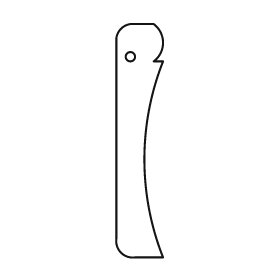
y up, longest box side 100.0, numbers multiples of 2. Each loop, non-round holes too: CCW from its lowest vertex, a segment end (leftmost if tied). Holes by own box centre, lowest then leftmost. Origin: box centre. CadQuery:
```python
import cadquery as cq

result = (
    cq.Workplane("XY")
    .moveTo(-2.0, -50.0)
    .lineTo(10.0, -50.0)
    .threePointArc((2.0, -8.0), (10.0, 34.0))
    .lineTo(6.0, 34.0)
    .threePointArc((10.0, 42.0), (6.0, 50.0))
    .lineTo(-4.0, 50.0)
    .threePointArc((-8.0, 48.0), (-10.0, 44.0))
    .lineTo(-10.0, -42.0)
    .threePointArc((-8.0, -48.0), (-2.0, -50.0))
    .close()
    .moveTo(-4.0, 36.0)
    .circle(2.0)
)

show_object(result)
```